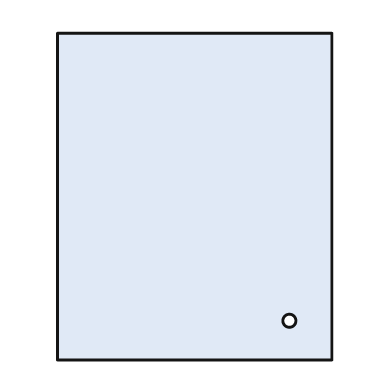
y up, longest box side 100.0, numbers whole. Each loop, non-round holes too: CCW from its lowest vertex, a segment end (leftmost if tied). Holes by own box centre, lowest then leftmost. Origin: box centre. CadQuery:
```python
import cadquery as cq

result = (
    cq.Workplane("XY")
    .moveTo(-42.0, -50.0)
    .lineTo(42.0, -50.0)
    .lineTo(42.0, 50.0)
    .lineTo(-42.0, 50.0)
    .close()
    .moveTo(29.0, -38.0)
    .circle(2.0)
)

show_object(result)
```